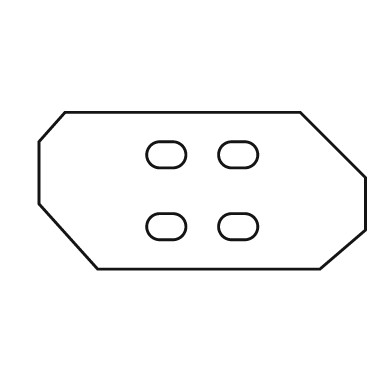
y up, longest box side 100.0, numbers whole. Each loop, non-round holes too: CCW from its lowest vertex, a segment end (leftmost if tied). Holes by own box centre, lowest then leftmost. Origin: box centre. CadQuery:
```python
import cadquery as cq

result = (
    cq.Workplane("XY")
    .moveTo(-32.0, -24.0)
    .lineTo(36.0, -24.0)
    .lineTo(50.0, -12.0)
    .lineTo(50.0, 4.0)
    .lineTo(30.0, 24.0)
    .lineTo(-42.0, 24.0)
    .lineTo(-50.0, 15.0)
    .lineTo(-50.0, -4.0)
    .close()
    .moveTo(-13.0, -15.0)
    .lineTo(-9.0, -15.0)
    .threePointArc((-5.0, -11.0), (-9.0, -7.0))
    .lineTo(-13.0, -7.0)
    .threePointArc((-17.0, -11.0), (-13.0, -15.0))
    .close()
    .moveTo(9.0, -15.0)
    .lineTo(13.0, -15.0)
    .threePointArc((17.0, -11.0), (13.0, -7.0))
    .lineTo(9.0, -7.0)
    .threePointArc((5.0, -11.0), (9.0, -15.0))
    .close()
    .moveTo(-13.0, 7.0)
    .lineTo(-9.0, 7.0)
    .threePointArc((-5.0, 11.0), (-9.0, 15.0))
    .lineTo(-13.0, 15.0)
    .threePointArc((-17.0, 11.0), (-13.0, 7.0))
    .close()
    .moveTo(9.0, 7.0)
    .lineTo(13.0, 7.0)
    .threePointArc((17.0, 11.0), (13.0, 15.0))
    .lineTo(9.0, 15.0)
    .threePointArc((5.0, 11.0), (9.0, 7.0))
    .close()
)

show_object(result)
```